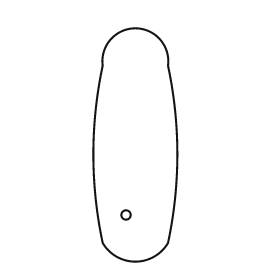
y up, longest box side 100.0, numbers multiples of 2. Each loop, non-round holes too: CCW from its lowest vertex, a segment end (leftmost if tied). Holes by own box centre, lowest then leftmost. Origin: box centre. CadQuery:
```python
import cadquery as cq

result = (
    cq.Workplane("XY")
    .moveTo(-14.0, -42.0)
    .threePointArc((0.0, -50.0), (14.0, -42.0))
    .threePointArc((18.0, -4.0), (14.0, 34.0))
    .threePointArc((0.0, 50.0), (-14.0, 34.0))
    .threePointArc((-18.0, -4.0), (-14.0, -42.0))
    .close()
    .moveTo(-4.0, -30.0)
    .circle(2.0)
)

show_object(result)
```